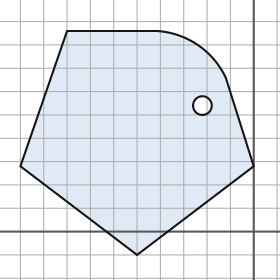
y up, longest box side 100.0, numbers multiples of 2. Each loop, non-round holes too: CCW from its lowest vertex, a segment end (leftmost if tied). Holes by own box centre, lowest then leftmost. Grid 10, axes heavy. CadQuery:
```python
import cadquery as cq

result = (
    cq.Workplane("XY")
    .moveTo(-50.0, -10.0)
    .lineTo(0.0, 28.0)
    .lineTo(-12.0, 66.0)
    .threePointArc((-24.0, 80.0), (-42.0, 86.0))
    .lineTo(-80.0, 86.0)
    .lineTo(-100.0, 28.0)
    .close()
    .moveTo(-22.0, 54.0)
    .circle(4.0)
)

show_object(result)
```